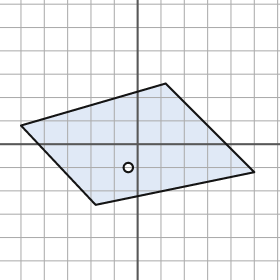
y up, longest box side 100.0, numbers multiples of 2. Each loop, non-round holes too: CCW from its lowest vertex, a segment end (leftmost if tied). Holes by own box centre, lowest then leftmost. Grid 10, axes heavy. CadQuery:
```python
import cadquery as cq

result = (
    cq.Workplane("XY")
    .moveTo(-18.0, -26.0)
    .lineTo(50.0, -12.0)
    .lineTo(12.0, 26.0)
    .lineTo(-50.0, 8.0)
    .close()
    .moveTo(-4.0, -10.0)
    .circle(2.0)
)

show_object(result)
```